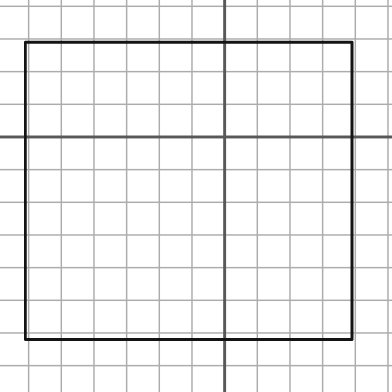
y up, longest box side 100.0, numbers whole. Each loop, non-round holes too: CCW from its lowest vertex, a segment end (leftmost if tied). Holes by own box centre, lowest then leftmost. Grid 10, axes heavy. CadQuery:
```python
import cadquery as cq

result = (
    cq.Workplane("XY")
    .moveTo(-61.0, -62.0)
    .lineTo(39.0, -62.0)
    .lineTo(39.0, 29.0)
    .lineTo(-61.0, 29.0)
    .close()
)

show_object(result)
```